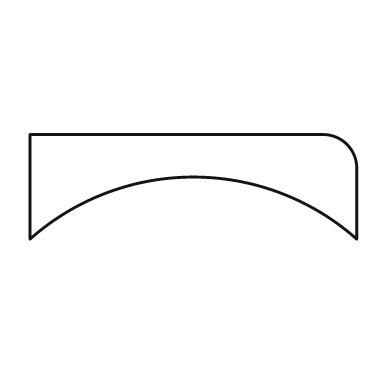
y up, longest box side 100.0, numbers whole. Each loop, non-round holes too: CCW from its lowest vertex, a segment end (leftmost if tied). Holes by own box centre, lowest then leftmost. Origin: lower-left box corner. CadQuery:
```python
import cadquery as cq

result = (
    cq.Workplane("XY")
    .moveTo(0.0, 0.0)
    .threePointArc((50.0, 19.0), (100.0, 0.0))
    .lineTo(100.0, 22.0)
    .threePointArc((97.0, 29.0), (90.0, 32.0))
    .lineTo(0.0, 32.0)
    .close()
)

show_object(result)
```